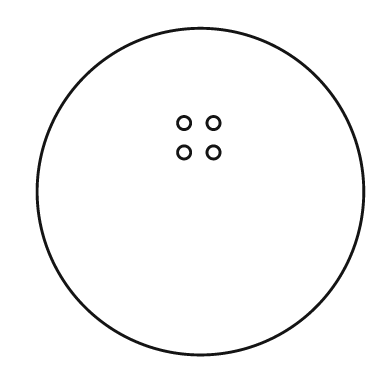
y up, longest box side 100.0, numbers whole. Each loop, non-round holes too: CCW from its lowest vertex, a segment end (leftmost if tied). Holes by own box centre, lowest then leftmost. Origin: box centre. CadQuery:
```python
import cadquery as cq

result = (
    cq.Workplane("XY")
    .moveTo(0.0, 0.0)
    .circle(50.0)
    .moveTo(-5.0, 12.0)
    .circle(2.0)
    .moveTo(4.0, 12.0)
    .circle(2.0)
    .moveTo(-5.0, 21.0)
    .circle(2.0)
    .moveTo(4.0, 21.0)
    .circle(2.0)
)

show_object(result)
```